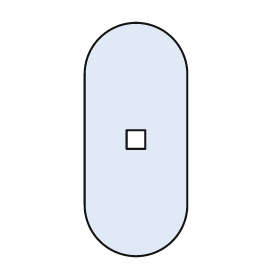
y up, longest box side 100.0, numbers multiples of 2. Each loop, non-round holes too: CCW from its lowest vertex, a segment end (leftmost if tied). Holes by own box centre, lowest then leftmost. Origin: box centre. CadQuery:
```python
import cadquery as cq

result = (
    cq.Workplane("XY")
    .moveTo(-22.0, -28.0)
    .threePointArc((0.0, -50.0), (22.0, -28.0))
    .lineTo(22.0, 28.0)
    .threePointArc((0.0, 50.0), (-22.0, 28.0))
    .close()
    .moveTo(-4.0, -4.0)
    .lineTo(4.0, -4.0)
    .lineTo(4.0, 4.0)
    .lineTo(-4.0, 4.0)
    .close()
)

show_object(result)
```